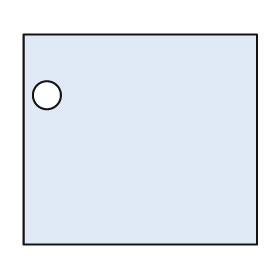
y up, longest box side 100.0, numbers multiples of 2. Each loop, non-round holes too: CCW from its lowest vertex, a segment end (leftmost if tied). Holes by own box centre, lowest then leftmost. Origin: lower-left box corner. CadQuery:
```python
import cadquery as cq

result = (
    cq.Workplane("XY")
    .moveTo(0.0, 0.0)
    .lineTo(100.0, 0.0)
    .lineTo(100.0, 90.0)
    .lineTo(0.0, 90.0)
    .close()
    .moveTo(10.0, 64.0)
    .circle(6.0)
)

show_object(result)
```